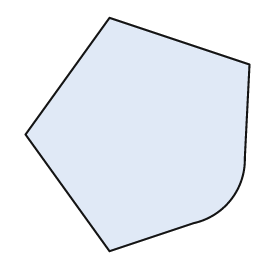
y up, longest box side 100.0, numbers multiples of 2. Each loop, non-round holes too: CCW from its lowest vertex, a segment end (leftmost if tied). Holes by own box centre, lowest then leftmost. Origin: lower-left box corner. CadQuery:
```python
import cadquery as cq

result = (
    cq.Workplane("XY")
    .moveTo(36.0, 0.0)
    .lineTo(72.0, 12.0)
    .threePointArc((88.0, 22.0), (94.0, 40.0))
    .lineTo(96.0, 80.0)
    .lineTo(36.0, 100.0)
    .lineTo(0.0, 50.0)
    .close()
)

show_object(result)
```